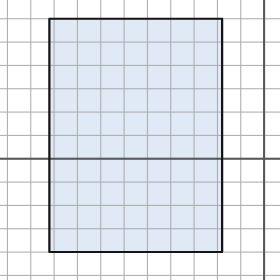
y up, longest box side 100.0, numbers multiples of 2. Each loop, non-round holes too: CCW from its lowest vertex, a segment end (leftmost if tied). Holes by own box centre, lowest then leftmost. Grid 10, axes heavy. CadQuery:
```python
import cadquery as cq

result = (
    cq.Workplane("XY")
    .moveTo(-92.0, -40.0)
    .lineTo(-18.0, -40.0)
    .lineTo(-18.0, 60.0)
    .lineTo(-92.0, 60.0)
    .close()
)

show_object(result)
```